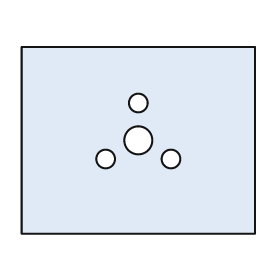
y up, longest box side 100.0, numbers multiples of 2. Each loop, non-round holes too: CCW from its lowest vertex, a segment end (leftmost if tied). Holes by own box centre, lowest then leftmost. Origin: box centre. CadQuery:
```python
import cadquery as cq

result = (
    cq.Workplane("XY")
    .moveTo(-50.0, -40.0)
    .lineTo(50.0, -40.0)
    .lineTo(50.0, 40.0)
    .lineTo(-50.0, 40.0)
    .close()
    .moveTo(-14.0, -8.0)
    .circle(4.0)
    .moveTo(14.0, -8.0)
    .circle(4.0)
    .moveTo(0.0, 0.0)
    .circle(6.0)
    .moveTo(0.0, 16.0)
    .circle(4.0)
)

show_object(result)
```